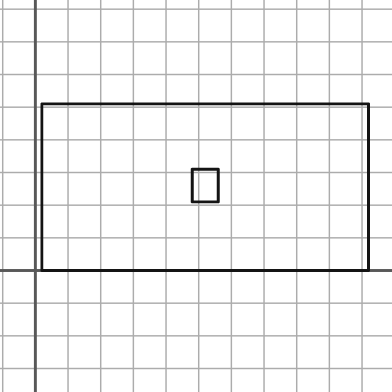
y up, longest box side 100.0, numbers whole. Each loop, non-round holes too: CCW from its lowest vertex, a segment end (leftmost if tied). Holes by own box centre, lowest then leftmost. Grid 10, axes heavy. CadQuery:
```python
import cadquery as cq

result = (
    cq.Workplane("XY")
    .moveTo(2.0, 0.0)
    .lineTo(102.0, 0.0)
    .lineTo(102.0, 51.0)
    .lineTo(2.0, 51.0)
    .close()
    .moveTo(48.0, 21.0)
    .lineTo(56.0, 21.0)
    .lineTo(56.0, 31.0)
    .lineTo(48.0, 31.0)
    .close()
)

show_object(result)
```